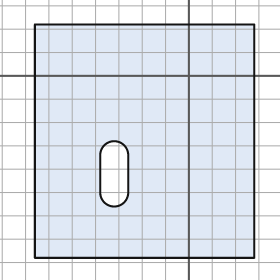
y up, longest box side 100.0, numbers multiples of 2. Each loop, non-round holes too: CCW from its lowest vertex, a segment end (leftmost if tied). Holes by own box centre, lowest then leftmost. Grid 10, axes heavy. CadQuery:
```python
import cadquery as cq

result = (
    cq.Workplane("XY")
    .moveTo(-66.0, -78.0)
    .lineTo(28.0, -78.0)
    .lineTo(28.0, 22.0)
    .lineTo(-66.0, 22.0)
    .close()
    .moveTo(-38.0, -50.0)
    .threePointArc((-32.0, -56.0), (-26.0, -50.0))
    .lineTo(-26.0, -34.0)
    .threePointArc((-32.0, -28.0), (-38.0, -34.0))
    .close()
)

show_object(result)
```